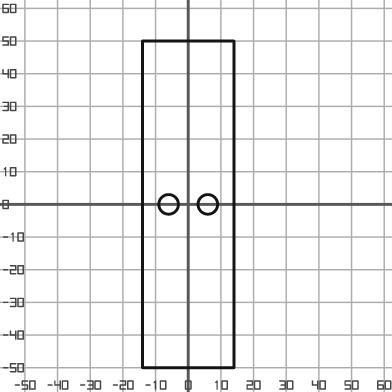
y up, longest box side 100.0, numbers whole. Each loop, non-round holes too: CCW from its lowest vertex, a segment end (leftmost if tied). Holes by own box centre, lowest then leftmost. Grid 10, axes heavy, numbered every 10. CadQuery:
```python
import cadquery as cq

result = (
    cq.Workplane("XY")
    .moveTo(-14.0, -50.0)
    .lineTo(14.0, -50.0)
    .lineTo(14.0, 50.0)
    .lineTo(-14.0, 50.0)
    .close()
    .moveTo(-6.0, 0.0)
    .circle(3.0)
    .moveTo(6.0, 0.0)
    .circle(3.0)
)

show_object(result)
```